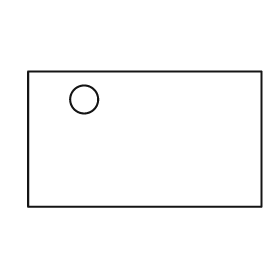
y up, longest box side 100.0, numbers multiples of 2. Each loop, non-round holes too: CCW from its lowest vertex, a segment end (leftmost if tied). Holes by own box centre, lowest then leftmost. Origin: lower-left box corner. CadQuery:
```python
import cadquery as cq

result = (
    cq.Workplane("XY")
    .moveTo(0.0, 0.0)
    .lineTo(100.0, 0.0)
    .lineTo(100.0, 58.0)
    .lineTo(0.0, 58.0)
    .close()
    .moveTo(24.0, 46.0)
    .circle(6.0)
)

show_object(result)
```